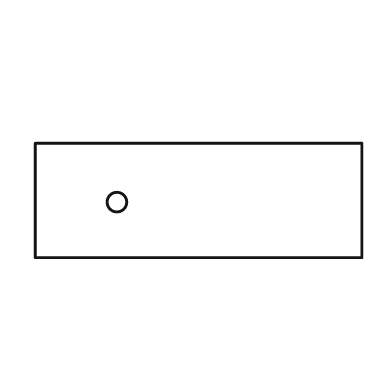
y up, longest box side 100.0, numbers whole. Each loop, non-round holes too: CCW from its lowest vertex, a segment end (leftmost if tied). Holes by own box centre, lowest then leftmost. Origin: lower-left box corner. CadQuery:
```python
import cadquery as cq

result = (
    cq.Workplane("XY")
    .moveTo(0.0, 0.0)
    .lineTo(100.0, 0.0)
    .lineTo(100.0, 35.0)
    .lineTo(0.0, 35.0)
    .close()
    .moveTo(25.0, 17.0)
    .circle(3.0)
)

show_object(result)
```